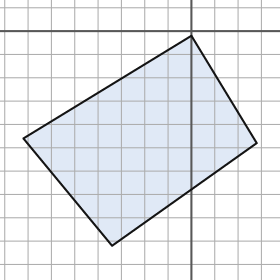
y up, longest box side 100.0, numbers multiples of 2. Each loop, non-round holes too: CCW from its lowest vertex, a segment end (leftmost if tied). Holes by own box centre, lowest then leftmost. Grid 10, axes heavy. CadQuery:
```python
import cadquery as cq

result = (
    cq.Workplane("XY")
    .moveTo(-34.0, -92.0)
    .lineTo(28.0, -48.0)
    .lineTo(0.0, -2.0)
    .lineTo(-72.0, -46.0)
    .close()
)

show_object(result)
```